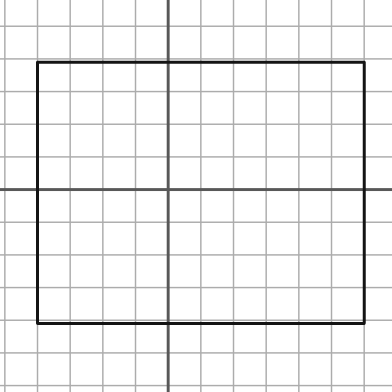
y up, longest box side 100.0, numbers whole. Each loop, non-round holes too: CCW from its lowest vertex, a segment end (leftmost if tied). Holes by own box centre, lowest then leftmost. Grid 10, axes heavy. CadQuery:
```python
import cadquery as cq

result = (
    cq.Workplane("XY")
    .moveTo(-40.0, -41.0)
    .lineTo(60.0, -41.0)
    .lineTo(60.0, 39.0)
    .lineTo(-40.0, 39.0)
    .close()
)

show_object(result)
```